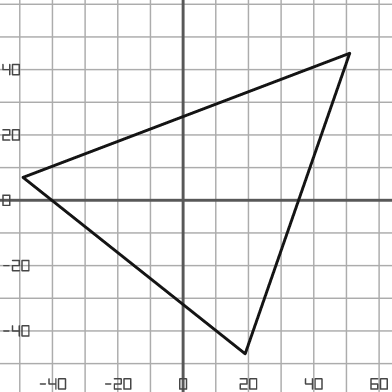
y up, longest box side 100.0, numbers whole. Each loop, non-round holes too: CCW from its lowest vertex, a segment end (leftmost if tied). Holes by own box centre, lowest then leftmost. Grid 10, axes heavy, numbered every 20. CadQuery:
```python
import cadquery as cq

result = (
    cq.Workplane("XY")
    .moveTo(19.0, -47.0)
    .lineTo(51.0, 45.0)
    .lineTo(-49.0, 7.0)
    .close()
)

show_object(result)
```